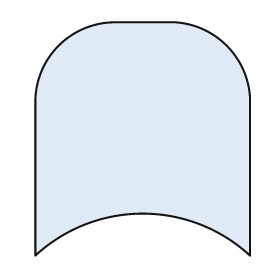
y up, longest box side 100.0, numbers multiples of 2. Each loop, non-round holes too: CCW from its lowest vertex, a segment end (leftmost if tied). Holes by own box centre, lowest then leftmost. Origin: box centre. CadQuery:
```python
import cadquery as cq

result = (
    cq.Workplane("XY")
    .moveTo(-46.0, -50.0)
    .threePointArc((0.0, -32.0), (46.0, -50.0))
    .lineTo(46.0, 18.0)
    .threePointArc((36.0, 40.0), (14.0, 50.0))
    .lineTo(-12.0, 50.0)
    .threePointArc((-36.0, 40.0), (-46.0, 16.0))
    .close()
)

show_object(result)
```